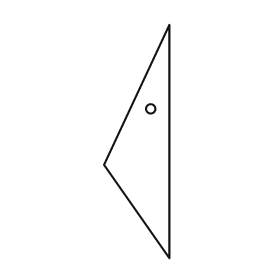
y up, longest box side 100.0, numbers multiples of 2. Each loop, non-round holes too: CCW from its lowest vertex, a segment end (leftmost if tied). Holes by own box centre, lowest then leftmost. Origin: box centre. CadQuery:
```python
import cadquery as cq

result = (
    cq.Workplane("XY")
    .moveTo(14.0, -50.0)
    .lineTo(14.0, 50.0)
    .lineTo(-14.0, -10.0)
    .close()
    .moveTo(6.0, 14.0)
    .circle(2.0)
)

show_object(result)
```